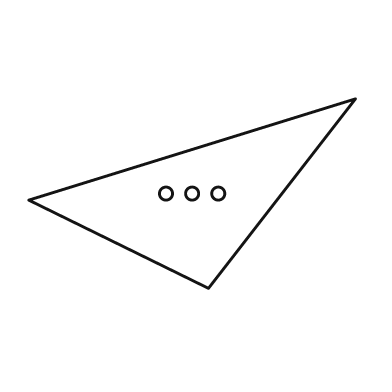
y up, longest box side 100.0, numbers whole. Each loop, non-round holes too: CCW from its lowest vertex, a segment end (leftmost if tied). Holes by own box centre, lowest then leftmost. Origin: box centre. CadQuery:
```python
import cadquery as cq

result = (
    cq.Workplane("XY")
    .moveTo(5.0, -29.0)
    .lineTo(50.0, 29.0)
    .lineTo(-50.0, -2.0)
    .close()
    .moveTo(-8.0, 0.0)
    .circle(2.0)
    .moveTo(0.0, 0.0)
    .circle(2.0)
    .moveTo(8.0, 0.0)
    .circle(2.0)
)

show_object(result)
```